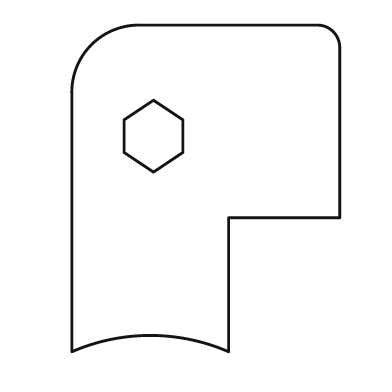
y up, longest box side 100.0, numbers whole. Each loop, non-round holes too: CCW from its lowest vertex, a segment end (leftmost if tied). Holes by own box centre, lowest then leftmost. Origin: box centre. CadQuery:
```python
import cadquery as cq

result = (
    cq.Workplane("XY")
    .moveTo(-41.0, -50.0)
    .threePointArc((-17.0, -45.0), (7.0, -50.0))
    .lineTo(7.0, -9.0)
    .lineTo(41.0, -9.0)
    .lineTo(41.0, 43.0)
    .threePointArc((39.0, 48.0), (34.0, 50.0))
    .lineTo(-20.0, 50.0)
    .threePointArc((-35.0, 44.0), (-41.0, 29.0))
    .close()
    .moveTo(-16.0, 5.0)
    .lineTo(-7.0, 11.0)
    .lineTo(-7.0, 21.0)
    .lineTo(-16.0, 27.0)
    .lineTo(-25.0, 21.0)
    .lineTo(-25.0, 11.0)
    .close()
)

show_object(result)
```